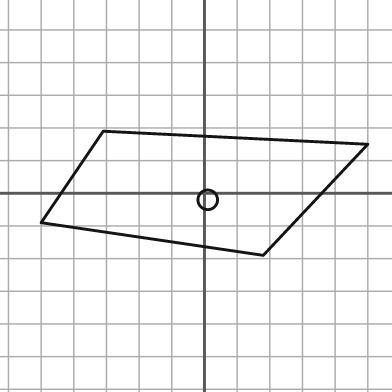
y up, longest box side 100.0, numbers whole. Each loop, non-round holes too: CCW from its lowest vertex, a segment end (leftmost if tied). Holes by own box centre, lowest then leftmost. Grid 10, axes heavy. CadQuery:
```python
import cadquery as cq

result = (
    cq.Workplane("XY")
    .moveTo(18.0, -19.0)
    .lineTo(50.0, 15.0)
    .lineTo(-31.0, 19.0)
    .lineTo(-50.0, -9.0)
    .close()
    .moveTo(1.0, -2.0)
    .circle(3.0)
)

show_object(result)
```